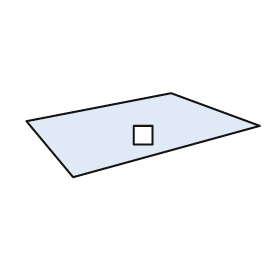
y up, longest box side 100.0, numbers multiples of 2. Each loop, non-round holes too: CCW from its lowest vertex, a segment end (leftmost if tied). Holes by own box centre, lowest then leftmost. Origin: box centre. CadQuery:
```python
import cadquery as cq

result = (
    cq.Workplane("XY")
    .moveTo(-30.0, -18.0)
    .lineTo(50.0, 4.0)
    .lineTo(12.0, 18.0)
    .lineTo(-50.0, 6.0)
    .close()
    .moveTo(-4.0, -4.0)
    .lineTo(4.0, -4.0)
    .lineTo(4.0, 4.0)
    .lineTo(-4.0, 4.0)
    .close()
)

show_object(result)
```